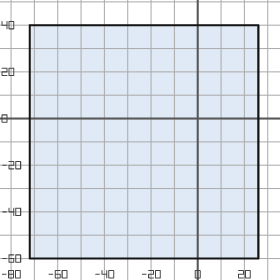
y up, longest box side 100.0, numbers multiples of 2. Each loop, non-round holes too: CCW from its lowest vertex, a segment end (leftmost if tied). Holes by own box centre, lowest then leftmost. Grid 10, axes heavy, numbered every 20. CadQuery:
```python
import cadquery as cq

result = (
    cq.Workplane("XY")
    .moveTo(-72.0, -60.0)
    .lineTo(26.0, -60.0)
    .lineTo(26.0, 40.0)
    .lineTo(-72.0, 40.0)
    .close()
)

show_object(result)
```